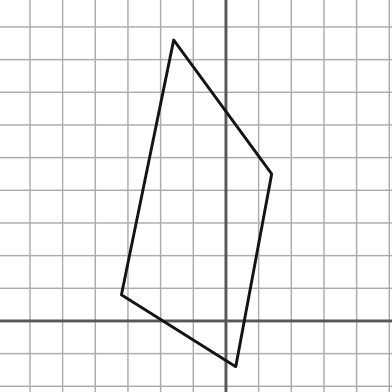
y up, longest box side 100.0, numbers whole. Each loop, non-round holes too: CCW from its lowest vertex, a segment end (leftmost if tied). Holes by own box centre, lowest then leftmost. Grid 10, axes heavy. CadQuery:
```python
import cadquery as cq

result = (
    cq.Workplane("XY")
    .moveTo(3.0, -14.0)
    .lineTo(14.0, 45.0)
    .lineTo(-16.0, 86.0)
    .lineTo(-32.0, 8.0)
    .close()
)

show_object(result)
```